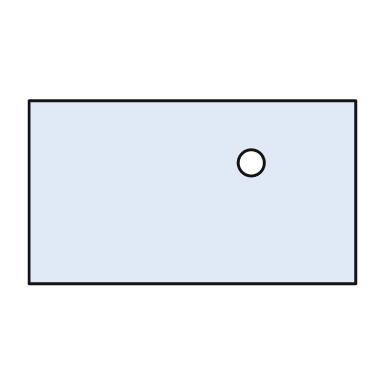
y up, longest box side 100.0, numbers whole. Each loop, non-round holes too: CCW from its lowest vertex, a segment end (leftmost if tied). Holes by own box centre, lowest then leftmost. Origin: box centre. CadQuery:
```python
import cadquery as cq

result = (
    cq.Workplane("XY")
    .moveTo(-50.0, -28.0)
    .lineTo(50.0, -28.0)
    .lineTo(50.0, 28.0)
    .lineTo(-50.0, 28.0)
    .close()
    .moveTo(18.0, 9.0)
    .circle(4.0)
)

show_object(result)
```